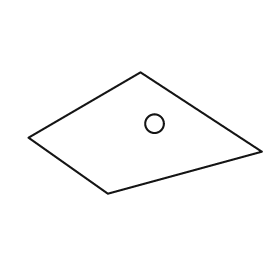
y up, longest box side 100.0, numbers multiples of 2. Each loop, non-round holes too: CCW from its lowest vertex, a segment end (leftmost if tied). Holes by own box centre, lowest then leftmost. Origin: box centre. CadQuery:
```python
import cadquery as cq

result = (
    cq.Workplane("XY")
    .moveTo(-16.0, -26.0)
    .lineTo(50.0, -8.0)
    .lineTo(-2.0, 26.0)
    .lineTo(-50.0, -2.0)
    .close()
    .moveTo(4.0, 4.0)
    .circle(4.0)
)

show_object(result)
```